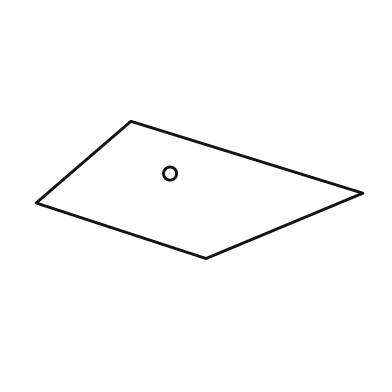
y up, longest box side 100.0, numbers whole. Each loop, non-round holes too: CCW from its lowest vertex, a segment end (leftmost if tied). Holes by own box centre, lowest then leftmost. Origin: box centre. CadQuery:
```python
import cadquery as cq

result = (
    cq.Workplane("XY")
    .moveTo(2.0, -21.0)
    .lineTo(50.0, -1.0)
    .lineTo(-21.0, 21.0)
    .lineTo(-50.0, -4.0)
    .close()
    .moveTo(-9.0, 5.0)
    .circle(2.0)
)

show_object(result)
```